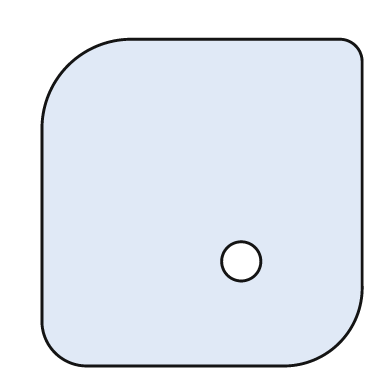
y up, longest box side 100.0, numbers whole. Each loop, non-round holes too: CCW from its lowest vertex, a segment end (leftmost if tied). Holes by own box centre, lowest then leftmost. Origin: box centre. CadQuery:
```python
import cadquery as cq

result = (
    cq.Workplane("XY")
    .moveTo(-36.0, -50.0)
    .lineTo(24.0, -50.0)
    .threePointArc((42.0, -43.0), (49.0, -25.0))
    .lineTo(49.0, 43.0)
    .threePointArc((47.0, 48.0), (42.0, 50.0))
    .lineTo(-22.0, 50.0)
    .threePointArc((-41.0, 42.0), (-49.0, 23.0))
    .lineTo(-49.0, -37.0)
    .threePointArc((-45.0, -46.0), (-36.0, -50.0))
    .close()
    .moveTo(12.0, -18.0)
    .circle(6.0)
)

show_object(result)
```